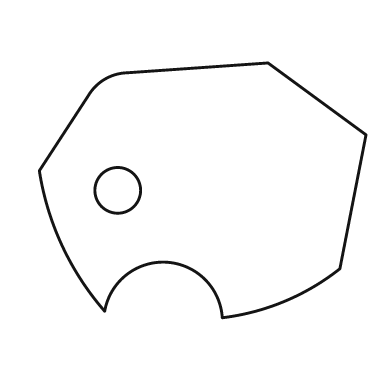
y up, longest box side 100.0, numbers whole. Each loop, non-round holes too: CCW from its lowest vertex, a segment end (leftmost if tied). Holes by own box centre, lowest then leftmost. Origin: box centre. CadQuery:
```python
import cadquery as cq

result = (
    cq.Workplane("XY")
    .moveTo(6.0, -39.0)
    .threePointArc((25.0, -34.0), (42.0, -24.0))
    .lineTo(50.0, 17.0)
    .lineTo(20.0, 39.0)
    .lineTo(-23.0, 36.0)
    .threePointArc((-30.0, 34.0), (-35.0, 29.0))
    .lineTo(-50.0, 6.0)
    .threePointArc((-43.0, -17.0), (-30.0, -37.0))
    .threePointArc((-11.0, -22.0), (6.0, -39.0))
    .close()
    .moveTo(-26.0, 0.0)
    .circle(7.0)
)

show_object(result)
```